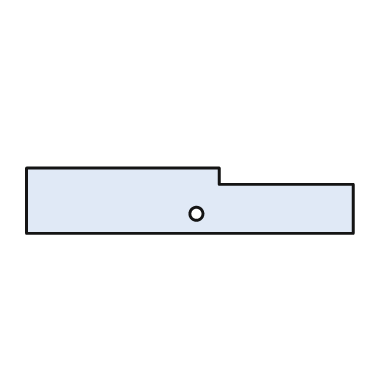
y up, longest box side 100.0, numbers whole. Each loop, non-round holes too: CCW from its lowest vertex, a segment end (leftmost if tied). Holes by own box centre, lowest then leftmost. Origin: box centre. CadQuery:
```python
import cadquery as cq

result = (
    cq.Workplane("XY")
    .moveTo(-50.0, -10.0)
    .lineTo(50.0, -10.0)
    .lineTo(50.0, 5.0)
    .lineTo(9.0, 5.0)
    .lineTo(9.0, 10.0)
    .lineTo(-50.0, 10.0)
    .close()
    .moveTo(2.0, -4.0)
    .circle(2.0)
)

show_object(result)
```